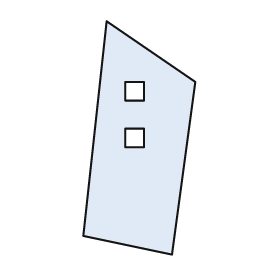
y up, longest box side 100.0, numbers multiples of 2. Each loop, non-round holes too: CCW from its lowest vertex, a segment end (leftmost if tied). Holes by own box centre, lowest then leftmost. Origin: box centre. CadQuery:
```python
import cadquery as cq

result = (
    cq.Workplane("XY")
    .moveTo(14.0, -50.0)
    .lineTo(24.0, 24.0)
    .lineTo(-14.0, 50.0)
    .lineTo(-24.0, -42.0)
    .close()
    .moveTo(-6.0, -4.0)
    .lineTo(2.0, -4.0)
    .lineTo(2.0, 4.0)
    .lineTo(-6.0, 4.0)
    .close()
    .moveTo(-6.0, 16.0)
    .lineTo(2.0, 16.0)
    .lineTo(2.0, 24.0)
    .lineTo(-6.0, 24.0)
    .close()
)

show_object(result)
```